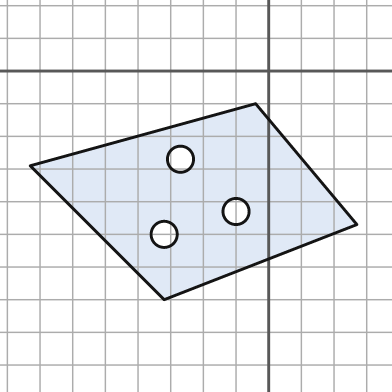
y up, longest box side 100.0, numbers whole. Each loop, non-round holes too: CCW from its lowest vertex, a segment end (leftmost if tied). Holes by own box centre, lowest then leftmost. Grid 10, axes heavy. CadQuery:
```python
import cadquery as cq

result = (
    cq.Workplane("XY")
    .moveTo(-32.0, -70.0)
    .lineTo(27.0, -47.0)
    .lineTo(-4.0, -10.0)
    .lineTo(-73.0, -29.0)
    .close()
    .moveTo(-32.0, -50.0)
    .circle(4.0)
    .moveTo(-10.0, -43.0)
    .circle(4.0)
    .moveTo(-27.0, -27.0)
    .circle(4.0)
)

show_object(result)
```